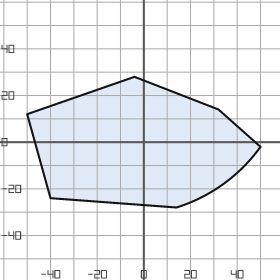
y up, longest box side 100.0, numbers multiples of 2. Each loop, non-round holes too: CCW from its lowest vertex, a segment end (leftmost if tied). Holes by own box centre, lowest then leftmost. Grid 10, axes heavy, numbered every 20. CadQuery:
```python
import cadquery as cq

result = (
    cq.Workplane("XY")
    .moveTo(14.0, -28.0)
    .threePointArc((34.0, -18.0), (50.0, -2.0))
    .lineTo(32.0, 14.0)
    .lineTo(-4.0, 28.0)
    .lineTo(-50.0, 12.0)
    .lineTo(-40.0, -24.0)
    .close()
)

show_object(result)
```